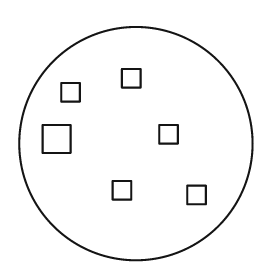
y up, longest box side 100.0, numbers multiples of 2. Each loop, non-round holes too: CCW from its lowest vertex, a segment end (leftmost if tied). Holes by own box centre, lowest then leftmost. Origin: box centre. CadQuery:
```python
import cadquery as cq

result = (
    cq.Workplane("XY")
    .moveTo(0.0, 0.0)
    .circle(50.0)
    .moveTo(22.0, -26.0)
    .lineTo(30.0, -26.0)
    .lineTo(30.0, -18.0)
    .lineTo(22.0, -18.0)
    .close()
    .moveTo(-10.0, -24.0)
    .lineTo(-2.0, -24.0)
    .lineTo(-2.0, -16.0)
    .lineTo(-10.0, -16.0)
    .close()
    .moveTo(-40.0, -4.0)
    .lineTo(-28.0, -4.0)
    .lineTo(-28.0, 8.0)
    .lineTo(-40.0, 8.0)
    .close()
    .moveTo(10.0, 0.0)
    .lineTo(18.0, 0.0)
    .lineTo(18.0, 8.0)
    .lineTo(10.0, 8.0)
    .close()
    .moveTo(-32.0, 18.0)
    .lineTo(-24.0, 18.0)
    .lineTo(-24.0, 26.0)
    .lineTo(-32.0, 26.0)
    .close()
    .moveTo(-6.0, 24.0)
    .lineTo(2.0, 24.0)
    .lineTo(2.0, 32.0)
    .lineTo(-6.0, 32.0)
    .close()
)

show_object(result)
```